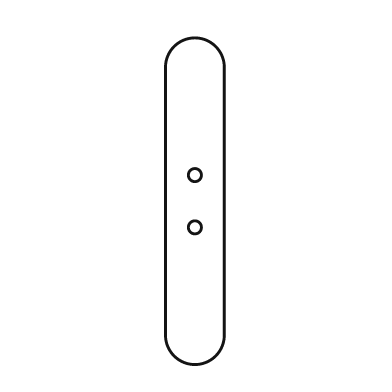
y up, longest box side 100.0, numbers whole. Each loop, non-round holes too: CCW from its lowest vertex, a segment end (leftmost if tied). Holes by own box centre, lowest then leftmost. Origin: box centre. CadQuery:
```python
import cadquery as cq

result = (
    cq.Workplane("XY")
    .moveTo(-9.0, -41.0)
    .threePointArc((0.0, -50.0), (9.0, -41.0))
    .lineTo(9.0, 41.0)
    .threePointArc((0.0, 50.0), (-9.0, 41.0))
    .close()
    .moveTo(0.0, -8.0)
    .circle(2.0)
    .moveTo(0.0, 8.0)
    .circle(2.0)
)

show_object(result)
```